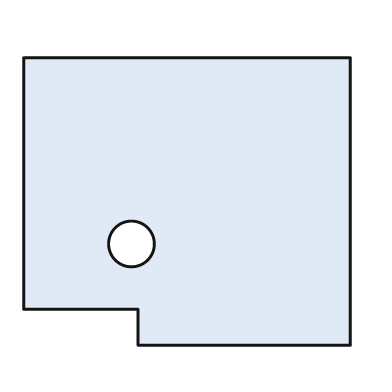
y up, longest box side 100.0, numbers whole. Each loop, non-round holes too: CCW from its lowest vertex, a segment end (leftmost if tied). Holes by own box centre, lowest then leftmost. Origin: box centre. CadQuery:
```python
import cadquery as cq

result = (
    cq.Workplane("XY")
    .moveTo(-15.0, -44.0)
    .lineTo(50.0, -44.0)
    .lineTo(50.0, 44.0)
    .lineTo(-50.0, 44.0)
    .lineTo(-50.0, -33.0)
    .lineTo(-15.0, -33.0)
    .close()
    .moveTo(-17.0, -13.0)
    .circle(7.0)
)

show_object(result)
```